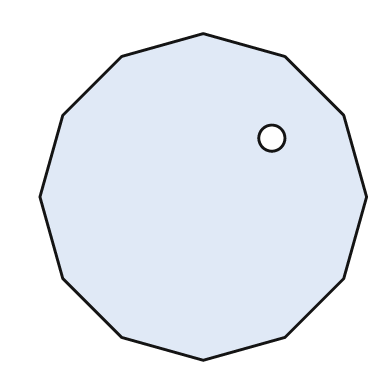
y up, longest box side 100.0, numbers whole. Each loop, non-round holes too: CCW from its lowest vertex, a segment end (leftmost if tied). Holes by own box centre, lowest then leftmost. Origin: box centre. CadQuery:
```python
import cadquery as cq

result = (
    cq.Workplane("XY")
    .moveTo(0.0, -50.0)
    .lineTo(25.0, -43.0)
    .lineTo(43.0, -25.0)
    .lineTo(50.0, 0.0)
    .lineTo(43.0, 25.0)
    .lineTo(25.0, 43.0)
    .lineTo(0.0, 50.0)
    .lineTo(-25.0, 43.0)
    .lineTo(-43.0, 25.0)
    .lineTo(-50.0, 0.0)
    .lineTo(-43.0, -25.0)
    .lineTo(-25.0, -43.0)
    .close()
    .moveTo(21.0, 18.0)
    .circle(4.0)
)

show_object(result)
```